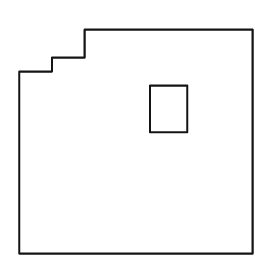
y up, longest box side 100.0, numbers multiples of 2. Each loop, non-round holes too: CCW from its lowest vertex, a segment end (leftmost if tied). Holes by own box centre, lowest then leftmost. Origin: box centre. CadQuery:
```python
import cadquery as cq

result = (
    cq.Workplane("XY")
    .moveTo(-50.0, -48.0)
    .lineTo(50.0, -48.0)
    .lineTo(50.0, 48.0)
    .lineTo(-22.0, 48.0)
    .lineTo(-22.0, 36.0)
    .lineTo(-36.0, 36.0)
    .lineTo(-36.0, 30.0)
    .lineTo(-50.0, 30.0)
    .close()
    .moveTo(6.0, 4.0)
    .lineTo(22.0, 4.0)
    .lineTo(22.0, 24.0)
    .lineTo(6.0, 24.0)
    .close()
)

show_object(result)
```